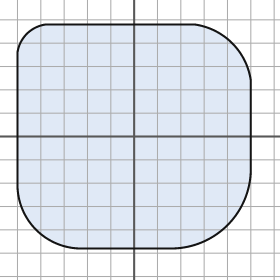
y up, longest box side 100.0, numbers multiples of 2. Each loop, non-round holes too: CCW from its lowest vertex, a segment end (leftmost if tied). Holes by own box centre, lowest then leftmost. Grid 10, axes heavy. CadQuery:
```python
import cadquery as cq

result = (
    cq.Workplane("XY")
    .moveTo(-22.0, -48.0)
    .lineTo(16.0, -48.0)
    .threePointArc((40.0, -38.0), (50.0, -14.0))
    .lineTo(50.0, 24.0)
    .threePointArc((42.0, 40.0), (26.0, 48.0))
    .lineTo(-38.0, 48.0)
    .threePointArc((-46.0, 44.0), (-50.0, 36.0))
    .lineTo(-50.0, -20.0)
    .threePointArc((-42.0, -40.0), (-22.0, -48.0))
    .close()
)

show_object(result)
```